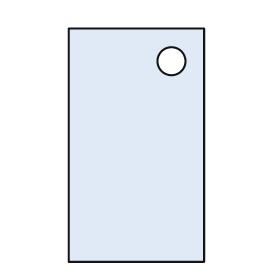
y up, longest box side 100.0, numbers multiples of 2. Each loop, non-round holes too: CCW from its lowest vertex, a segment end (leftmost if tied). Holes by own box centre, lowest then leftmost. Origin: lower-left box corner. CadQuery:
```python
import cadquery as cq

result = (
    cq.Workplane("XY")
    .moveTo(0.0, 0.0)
    .lineTo(58.0, 0.0)
    .lineTo(58.0, 100.0)
    .lineTo(0.0, 100.0)
    .close()
    .moveTo(44.0, 86.0)
    .circle(6.0)
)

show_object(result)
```